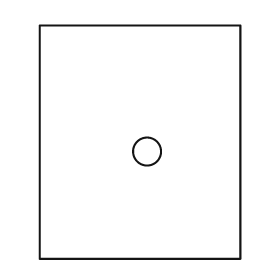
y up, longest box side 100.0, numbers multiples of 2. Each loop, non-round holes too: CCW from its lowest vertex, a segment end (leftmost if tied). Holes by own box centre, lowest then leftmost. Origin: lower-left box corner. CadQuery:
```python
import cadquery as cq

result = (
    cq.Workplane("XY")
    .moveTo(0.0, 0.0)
    .lineTo(86.0, 0.0)
    .lineTo(86.0, 100.0)
    .lineTo(0.0, 100.0)
    .close()
    .moveTo(46.0, 46.0)
    .circle(6.0)
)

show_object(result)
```